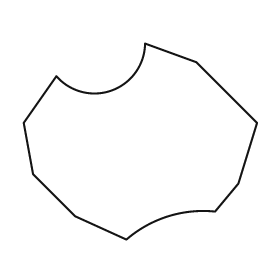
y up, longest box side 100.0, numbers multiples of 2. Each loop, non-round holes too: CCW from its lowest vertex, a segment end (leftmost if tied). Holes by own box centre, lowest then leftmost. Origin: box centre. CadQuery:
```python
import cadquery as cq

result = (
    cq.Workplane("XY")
    .moveTo(-6.0, -42.0)
    .threePointArc((12.0, -32.0), (32.0, -30.0))
    .lineTo(42.0, -18.0)
    .lineTo(50.0, 8.0)
    .lineTo(24.0, 34.0)
    .lineTo(2.0, 42.0)
    .threePointArc((-12.0, 22.0), (-36.0, 28.0))
    .lineTo(-50.0, 8.0)
    .lineTo(-46.0, -14.0)
    .lineTo(-28.0, -32.0)
    .close()
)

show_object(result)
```